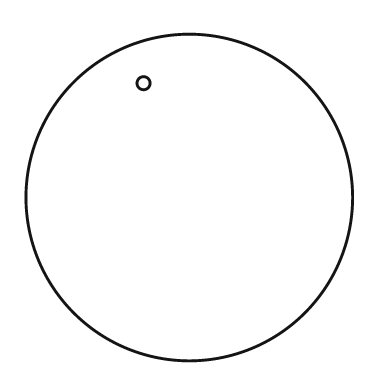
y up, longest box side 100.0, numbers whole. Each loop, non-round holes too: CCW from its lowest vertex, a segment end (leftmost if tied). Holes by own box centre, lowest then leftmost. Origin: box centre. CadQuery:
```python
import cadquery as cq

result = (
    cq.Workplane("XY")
    .moveTo(0.0, 0.0)
    .circle(50.0)
    .moveTo(-14.0, 35.0)
    .circle(2.0)
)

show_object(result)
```